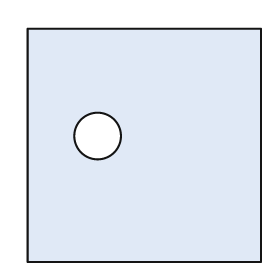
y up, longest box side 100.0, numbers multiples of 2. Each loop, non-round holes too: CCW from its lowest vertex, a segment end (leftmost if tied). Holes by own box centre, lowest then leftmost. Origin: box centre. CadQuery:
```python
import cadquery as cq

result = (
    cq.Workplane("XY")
    .moveTo(-50.0, -50.0)
    .lineTo(50.0, -50.0)
    .lineTo(50.0, 50.0)
    .lineTo(-50.0, 50.0)
    .close()
    .moveTo(-20.0, 4.0)
    .circle(10.0)
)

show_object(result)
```